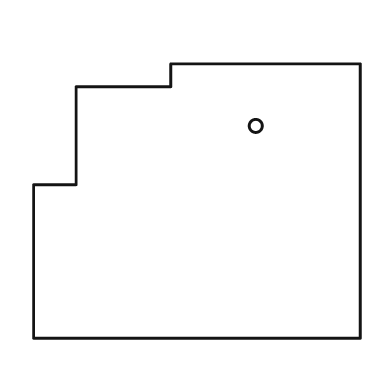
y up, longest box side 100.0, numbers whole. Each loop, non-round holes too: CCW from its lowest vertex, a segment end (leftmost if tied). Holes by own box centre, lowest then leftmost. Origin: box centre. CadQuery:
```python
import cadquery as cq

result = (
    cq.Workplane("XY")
    .moveTo(-50.0, -42.0)
    .lineTo(50.0, -42.0)
    .lineTo(50.0, 42.0)
    .lineTo(-8.0, 42.0)
    .lineTo(-8.0, 35.0)
    .lineTo(-37.0, 35.0)
    .lineTo(-37.0, 5.0)
    .lineTo(-50.0, 5.0)
    .close()
    .moveTo(18.0, 23.0)
    .circle(2.0)
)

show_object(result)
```